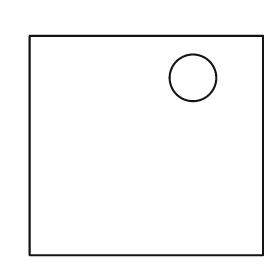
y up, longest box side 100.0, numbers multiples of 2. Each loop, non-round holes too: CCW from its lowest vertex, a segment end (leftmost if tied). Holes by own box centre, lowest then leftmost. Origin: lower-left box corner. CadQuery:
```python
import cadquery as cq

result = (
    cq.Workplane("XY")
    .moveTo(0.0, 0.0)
    .lineTo(100.0, 0.0)
    .lineTo(100.0, 94.0)
    .lineTo(0.0, 94.0)
    .close()
    .moveTo(70.0, 76.0)
    .circle(10.0)
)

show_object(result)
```